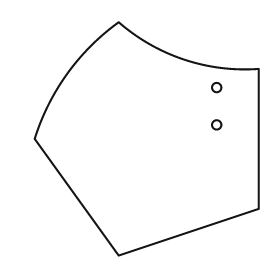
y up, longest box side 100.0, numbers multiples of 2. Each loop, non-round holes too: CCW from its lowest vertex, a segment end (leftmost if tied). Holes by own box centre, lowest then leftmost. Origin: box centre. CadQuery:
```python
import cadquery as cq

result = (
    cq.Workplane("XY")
    .moveTo(-12.0, -50.0)
    .lineTo(48.0, -30.0)
    .lineTo(48.0, 30.0)
    .threePointArc((16.0, 34.0), (-12.0, 50.0))
    .threePointArc((-34.0, 28.0), (-48.0, 0.0))
    .close()
    .moveTo(30.0, 6.0)
    .circle(2.0)
    .moveTo(30.0, 22.0)
    .circle(2.0)
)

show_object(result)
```